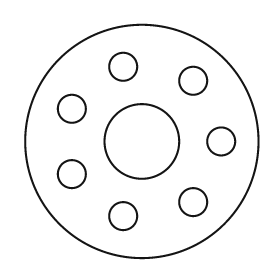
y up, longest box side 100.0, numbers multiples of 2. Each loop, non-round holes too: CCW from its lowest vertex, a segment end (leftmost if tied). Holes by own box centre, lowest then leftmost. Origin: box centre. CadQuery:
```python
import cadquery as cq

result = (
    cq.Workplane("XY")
    .moveTo(0.0, 0.0)
    .circle(50.0)
    .moveTo(-8.0, -32.0)
    .circle(6.0)
    .moveTo(22.0, -26.0)
    .circle(6.0)
    .moveTo(-30.0, -14.0)
    .circle(6.0)
    .moveTo(0.0, 0.0)
    .circle(16.0)
    .moveTo(34.0, 0.0)
    .circle(6.0)
    .moveTo(-30.0, 14.0)
    .circle(6.0)
    .moveTo(22.0, 26.0)
    .circle(6.0)
    .moveTo(-8.0, 32.0)
    .circle(6.0)
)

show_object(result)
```